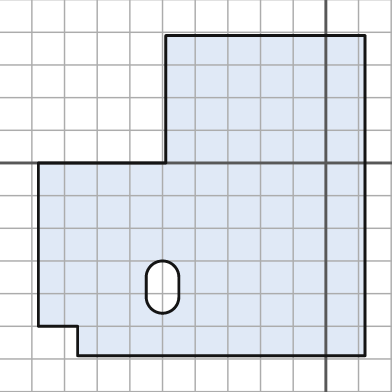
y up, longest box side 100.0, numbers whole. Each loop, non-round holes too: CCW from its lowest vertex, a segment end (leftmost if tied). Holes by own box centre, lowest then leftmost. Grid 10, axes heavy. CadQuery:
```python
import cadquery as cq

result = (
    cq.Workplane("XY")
    .moveTo(-76.0, -59.0)
    .lineTo(12.0, -59.0)
    .lineTo(12.0, 39.0)
    .lineTo(-49.0, 39.0)
    .lineTo(-49.0, 0.0)
    .lineTo(-88.0, 0.0)
    .lineTo(-88.0, -50.0)
    .lineTo(-76.0, -50.0)
    .close()
    .moveTo(-55.0, -41.0)
    .threePointArc((-50.0, -46.0), (-45.0, -41.0))
    .lineTo(-45.0, -35.0)
    .threePointArc((-50.0, -30.0), (-55.0, -35.0))
    .close()
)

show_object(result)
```